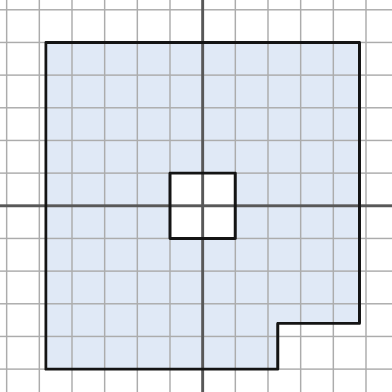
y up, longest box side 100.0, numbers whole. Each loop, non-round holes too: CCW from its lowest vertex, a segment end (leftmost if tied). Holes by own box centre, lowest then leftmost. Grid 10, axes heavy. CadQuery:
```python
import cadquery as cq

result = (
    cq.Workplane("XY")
    .moveTo(-48.0, -50.0)
    .lineTo(23.0, -50.0)
    .lineTo(23.0, -36.0)
    .lineTo(48.0, -36.0)
    .lineTo(48.0, 50.0)
    .lineTo(-48.0, 50.0)
    .close()
    .moveTo(-10.0, -10.0)
    .lineTo(10.0, -10.0)
    .lineTo(10.0, 10.0)
    .lineTo(-10.0, 10.0)
    .close()
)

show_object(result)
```